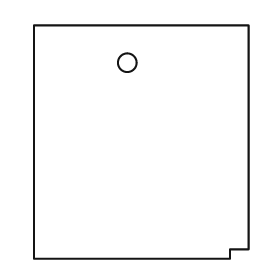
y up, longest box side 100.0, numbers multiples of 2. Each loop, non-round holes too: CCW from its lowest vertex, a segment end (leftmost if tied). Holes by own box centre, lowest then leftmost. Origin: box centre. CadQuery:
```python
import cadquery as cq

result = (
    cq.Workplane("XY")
    .moveTo(-46.0, -50.0)
    .lineTo(38.0, -50.0)
    .lineTo(38.0, -46.0)
    .lineTo(46.0, -46.0)
    .lineTo(46.0, 50.0)
    .lineTo(-46.0, 50.0)
    .close()
    .moveTo(-6.0, 34.0)
    .circle(4.0)
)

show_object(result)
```